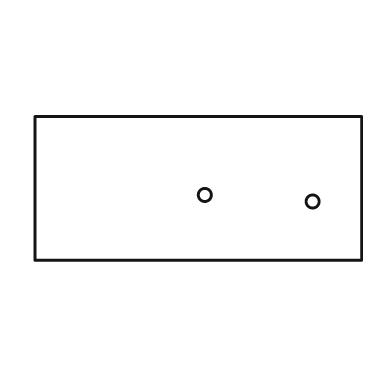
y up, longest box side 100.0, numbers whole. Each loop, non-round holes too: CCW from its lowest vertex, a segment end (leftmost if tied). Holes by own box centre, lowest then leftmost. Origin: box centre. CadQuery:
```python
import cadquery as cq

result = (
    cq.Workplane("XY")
    .moveTo(-50.0, -22.0)
    .lineTo(50.0, -22.0)
    .lineTo(50.0, 22.0)
    .lineTo(-50.0, 22.0)
    .close()
    .moveTo(35.0, -4.0)
    .circle(2.0)
    .moveTo(2.0, -2.0)
    .circle(2.0)
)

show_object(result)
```